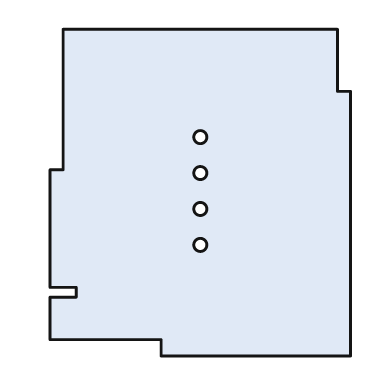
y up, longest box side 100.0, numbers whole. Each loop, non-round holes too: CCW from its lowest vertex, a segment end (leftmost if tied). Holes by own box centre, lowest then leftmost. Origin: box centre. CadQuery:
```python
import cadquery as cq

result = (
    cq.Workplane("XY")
    .moveTo(-12.0, -50.0)
    .lineTo(46.0, -50.0)
    .lineTo(46.0, 31.0)
    .lineTo(42.0, 31.0)
    .lineTo(42.0, 50.0)
    .lineTo(-42.0, 50.0)
    .lineTo(-42.0, 7.0)
    .lineTo(-46.0, 7.0)
    .lineTo(-46.0, -29.0)
    .lineTo(-38.0, -29.0)
    .lineTo(-38.0, -32.0)
    .lineTo(-46.0, -32.0)
    .lineTo(-46.0, -45.0)
    .lineTo(-12.0, -45.0)
    .close()
    .moveTo(0.0, -16.0)
    .circle(2.0)
    .moveTo(0.0, -5.0)
    .circle(2.0)
    .moveTo(0.0, 6.0)
    .circle(2.0)
    .moveTo(0.0, 17.0)
    .circle(2.0)
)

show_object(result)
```